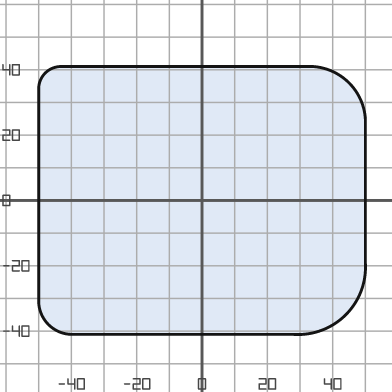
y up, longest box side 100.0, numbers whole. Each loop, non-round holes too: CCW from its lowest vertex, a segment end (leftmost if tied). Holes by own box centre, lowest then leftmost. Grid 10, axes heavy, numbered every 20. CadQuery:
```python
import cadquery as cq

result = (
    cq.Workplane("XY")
    .moveTo(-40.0, -41.0)
    .lineTo(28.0, -41.0)
    .threePointArc((44.0, -35.0), (50.0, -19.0))
    .lineTo(50.0, 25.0)
    .threePointArc((45.0, 36.0), (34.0, 41.0))
    .lineTo(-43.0, 41.0)
    .threePointArc((-48.0, 39.0), (-50.0, 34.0))
    .lineTo(-50.0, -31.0)
    .threePointArc((-47.0, -38.0), (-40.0, -41.0))
    .close()
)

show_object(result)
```